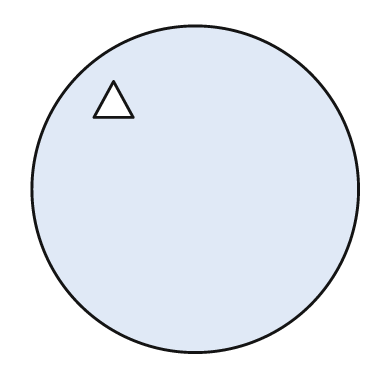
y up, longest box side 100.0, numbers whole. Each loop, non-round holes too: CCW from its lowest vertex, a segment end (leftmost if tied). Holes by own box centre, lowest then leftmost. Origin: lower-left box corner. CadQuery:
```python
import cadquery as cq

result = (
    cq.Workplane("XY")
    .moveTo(50.0, 50.0)
    .circle(50.0)
    .moveTo(19.0, 72.0)
    .lineTo(31.0, 72.0)
    .lineTo(25.0, 83.0)
    .close()
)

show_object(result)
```